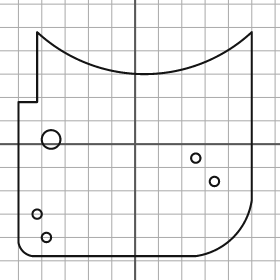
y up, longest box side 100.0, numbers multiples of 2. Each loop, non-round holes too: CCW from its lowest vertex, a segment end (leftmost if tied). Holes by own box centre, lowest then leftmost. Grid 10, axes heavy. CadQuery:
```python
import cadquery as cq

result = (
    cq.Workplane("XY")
    .moveTo(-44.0, -48.0)
    .lineTo(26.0, -48.0)
    .threePointArc((42.0, -40.0), (50.0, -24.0))
    .lineTo(50.0, 48.0)
    .threePointArc((4.0, 30.0), (-42.0, 48.0))
    .lineTo(-42.0, 18.0)
    .lineTo(-50.0, 18.0)
    .lineTo(-50.0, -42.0)
    .threePointArc((-48.0, -46.0), (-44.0, -48.0))
    .close()
    .moveTo(-38.0, -40.0)
    .circle(2.0)
    .moveTo(-42.0, -30.0)
    .circle(2.0)
    .moveTo(34.0, -16.0)
    .circle(2.0)
    .moveTo(26.0, -6.0)
    .circle(2.0)
    .moveTo(-36.0, 2.0)
    .circle(4.0)
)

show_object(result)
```